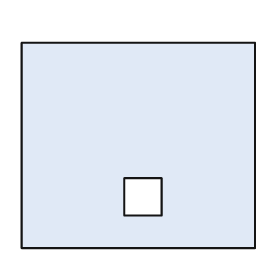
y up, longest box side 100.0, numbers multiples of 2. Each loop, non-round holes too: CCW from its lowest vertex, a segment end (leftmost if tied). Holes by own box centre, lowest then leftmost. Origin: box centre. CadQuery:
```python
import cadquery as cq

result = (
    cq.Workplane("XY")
    .moveTo(-50.0, -44.0)
    .lineTo(50.0, -44.0)
    .lineTo(50.0, 44.0)
    .lineTo(-50.0, 44.0)
    .close()
    .moveTo(-6.0, -30.0)
    .lineTo(10.0, -30.0)
    .lineTo(10.0, -14.0)
    .lineTo(-6.0, -14.0)
    .close()
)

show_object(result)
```